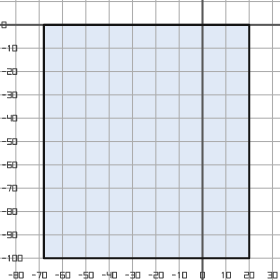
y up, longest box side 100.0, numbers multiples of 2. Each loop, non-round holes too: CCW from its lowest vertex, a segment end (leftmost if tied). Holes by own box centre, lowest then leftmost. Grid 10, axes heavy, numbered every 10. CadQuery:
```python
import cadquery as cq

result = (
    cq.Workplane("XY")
    .moveTo(-68.0, -100.0)
    .lineTo(20.0, -100.0)
    .lineTo(20.0, 0.0)
    .lineTo(-68.0, 0.0)
    .close()
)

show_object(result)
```